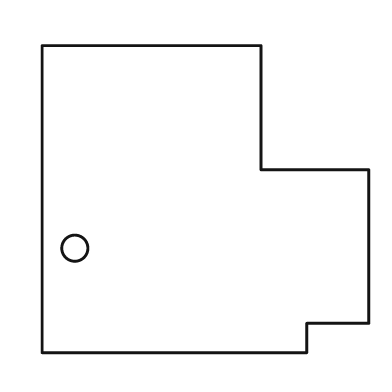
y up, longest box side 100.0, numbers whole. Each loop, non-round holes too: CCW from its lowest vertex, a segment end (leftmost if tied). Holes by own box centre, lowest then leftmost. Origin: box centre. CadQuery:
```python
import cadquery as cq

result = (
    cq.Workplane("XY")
    .moveTo(-50.0, -47.0)
    .lineTo(31.0, -47.0)
    .lineTo(31.0, -38.0)
    .lineTo(50.0, -38.0)
    .lineTo(50.0, 9.0)
    .lineTo(17.0, 9.0)
    .lineTo(17.0, 47.0)
    .lineTo(-50.0, 47.0)
    .close()
    .moveTo(-40.0, -15.0)
    .circle(4.0)
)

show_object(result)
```